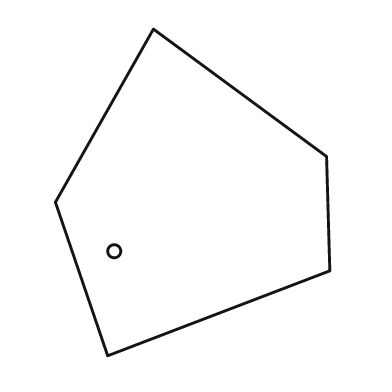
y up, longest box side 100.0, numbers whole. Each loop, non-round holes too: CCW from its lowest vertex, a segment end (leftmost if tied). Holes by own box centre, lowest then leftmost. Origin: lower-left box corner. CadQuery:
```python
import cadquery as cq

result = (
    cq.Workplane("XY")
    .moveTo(16.0, 0.0)
    .lineTo(84.0, 26.0)
    .lineTo(83.0, 61.0)
    .lineTo(30.0, 100.0)
    .lineTo(0.0, 47.0)
    .close()
    .moveTo(18.0, 32.0)
    .circle(2.0)
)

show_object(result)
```